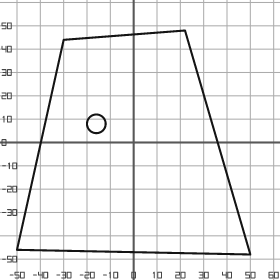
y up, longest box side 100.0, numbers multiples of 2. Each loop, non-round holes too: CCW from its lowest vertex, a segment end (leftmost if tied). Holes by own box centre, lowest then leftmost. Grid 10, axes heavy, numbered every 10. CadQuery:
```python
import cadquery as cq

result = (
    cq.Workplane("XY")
    .moveTo(50.0, -48.0)
    .lineTo(22.0, 48.0)
    .lineTo(-30.0, 44.0)
    .lineTo(-50.0, -46.0)
    .close()
    .moveTo(-16.0, 8.0)
    .circle(4.0)
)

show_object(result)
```